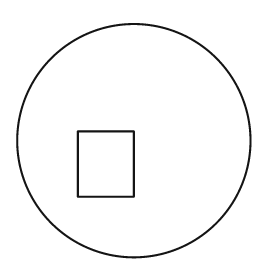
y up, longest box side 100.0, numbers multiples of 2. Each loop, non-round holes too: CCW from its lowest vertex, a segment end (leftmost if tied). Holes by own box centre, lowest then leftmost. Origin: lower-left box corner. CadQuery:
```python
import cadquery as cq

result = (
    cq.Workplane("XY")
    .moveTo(50.0, 50.0)
    .circle(50.0)
    .moveTo(26.0, 26.0)
    .lineTo(50.0, 26.0)
    .lineTo(50.0, 54.0)
    .lineTo(26.0, 54.0)
    .close()
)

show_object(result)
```